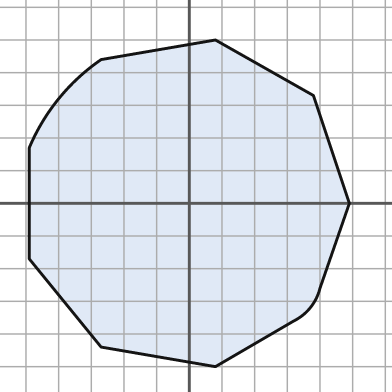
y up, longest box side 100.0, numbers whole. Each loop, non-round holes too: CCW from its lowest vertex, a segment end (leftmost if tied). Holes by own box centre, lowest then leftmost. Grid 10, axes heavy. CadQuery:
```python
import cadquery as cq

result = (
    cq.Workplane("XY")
    .moveTo(8.0, -50.0)
    .lineTo(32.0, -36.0)
    .threePointArc((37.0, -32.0), (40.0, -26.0))
    .lineTo(49.0, 0.0)
    .lineTo(38.0, 33.0)
    .lineTo(8.0, 50.0)
    .lineTo(-27.0, 44.0)
    .threePointArc((-40.0, 32.0), (-49.0, 17.0))
    .lineTo(-49.0, -17.0)
    .lineTo(-27.0, -44.0)
    .close()
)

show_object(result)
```